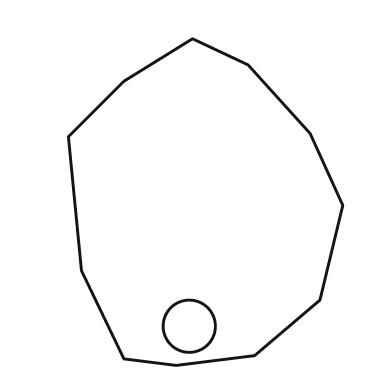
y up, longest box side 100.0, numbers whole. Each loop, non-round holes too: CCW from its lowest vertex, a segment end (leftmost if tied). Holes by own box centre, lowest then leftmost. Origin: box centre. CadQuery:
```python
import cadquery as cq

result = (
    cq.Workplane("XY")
    .moveTo(-9.0, -50.0)
    .lineTo(15.0, -47.0)
    .lineTo(35.0, -30.0)
    .lineTo(42.0, -1.0)
    .lineTo(32.0, 21.0)
    .lineTo(13.0, 42.0)
    .lineTo(-4.0, 50.0)
    .lineTo(-25.0, 37.0)
    .lineTo(-42.0, 20.0)
    .lineTo(-38.0, -21.0)
    .lineTo(-25.0, -48.0)
    .close()
    .moveTo(-5.0, -38.0)
    .circle(8.0)
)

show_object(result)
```